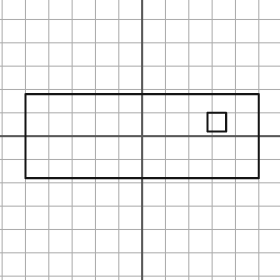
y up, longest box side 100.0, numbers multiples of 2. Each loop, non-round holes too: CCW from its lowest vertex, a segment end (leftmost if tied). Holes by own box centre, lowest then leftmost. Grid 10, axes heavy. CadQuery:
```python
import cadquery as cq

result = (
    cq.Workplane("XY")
    .moveTo(-50.0, -18.0)
    .lineTo(50.0, -18.0)
    .lineTo(50.0, 18.0)
    .lineTo(-50.0, 18.0)
    .close()
    .moveTo(28.0, 2.0)
    .lineTo(36.0, 2.0)
    .lineTo(36.0, 10.0)
    .lineTo(28.0, 10.0)
    .close()
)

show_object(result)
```